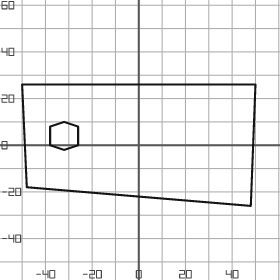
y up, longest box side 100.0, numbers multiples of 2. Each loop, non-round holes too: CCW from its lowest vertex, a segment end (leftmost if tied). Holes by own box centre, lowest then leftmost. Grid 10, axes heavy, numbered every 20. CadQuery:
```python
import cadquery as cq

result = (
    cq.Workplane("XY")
    .moveTo(48.0, -26.0)
    .lineTo(50.0, 26.0)
    .lineTo(-50.0, 26.0)
    .lineTo(-48.0, -18.0)
    .close()
    .moveTo(-32.0, -2.0)
    .lineTo(-26.0, 0.0)
    .lineTo(-26.0, 8.0)
    .lineTo(-32.0, 10.0)
    .lineTo(-38.0, 8.0)
    .lineTo(-38.0, 0.0)
    .close()
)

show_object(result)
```